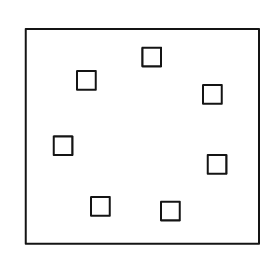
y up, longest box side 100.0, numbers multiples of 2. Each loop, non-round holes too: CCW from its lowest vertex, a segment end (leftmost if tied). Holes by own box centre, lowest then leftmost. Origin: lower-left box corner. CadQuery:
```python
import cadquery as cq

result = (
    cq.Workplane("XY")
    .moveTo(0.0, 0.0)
    .lineTo(100.0, 0.0)
    .lineTo(100.0, 92.0)
    .lineTo(0.0, 92.0)
    .close()
    .moveTo(58.0, 10.0)
    .lineTo(66.0, 10.0)
    .lineTo(66.0, 18.0)
    .lineTo(58.0, 18.0)
    .close()
    .moveTo(28.0, 12.0)
    .lineTo(36.0, 12.0)
    .lineTo(36.0, 20.0)
    .lineTo(28.0, 20.0)
    .close()
    .moveTo(78.0, 30.0)
    .lineTo(86.0, 30.0)
    .lineTo(86.0, 38.0)
    .lineTo(78.0, 38.0)
    .close()
    .moveTo(12.0, 38.0)
    .lineTo(20.0, 38.0)
    .lineTo(20.0, 46.0)
    .lineTo(12.0, 46.0)
    .close()
    .moveTo(76.0, 60.0)
    .lineTo(84.0, 60.0)
    .lineTo(84.0, 68.0)
    .lineTo(76.0, 68.0)
    .close()
    .moveTo(22.0, 66.0)
    .lineTo(30.0, 66.0)
    .lineTo(30.0, 74.0)
    .lineTo(22.0, 74.0)
    .close()
    .moveTo(50.0, 76.0)
    .lineTo(58.0, 76.0)
    .lineTo(58.0, 84.0)
    .lineTo(50.0, 84.0)
    .close()
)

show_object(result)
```